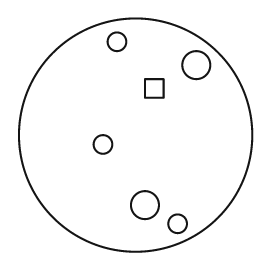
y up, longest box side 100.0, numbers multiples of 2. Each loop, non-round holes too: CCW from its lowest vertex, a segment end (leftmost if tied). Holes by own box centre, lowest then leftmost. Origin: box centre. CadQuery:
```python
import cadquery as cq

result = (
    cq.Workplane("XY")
    .moveTo(0.0, 0.0)
    .circle(50.0)
    .moveTo(18.0, -38.0)
    .circle(4.0)
    .moveTo(4.0, -30.0)
    .circle(6.0)
    .moveTo(-14.0, -4.0)
    .circle(4.0)
    .moveTo(4.0, 16.0)
    .lineTo(12.0, 16.0)
    .lineTo(12.0, 24.0)
    .lineTo(4.0, 24.0)
    .close()
    .moveTo(26.0, 30.0)
    .circle(6.0)
    .moveTo(-8.0, 40.0)
    .circle(4.0)
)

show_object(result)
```